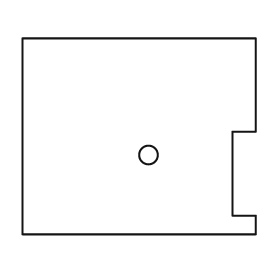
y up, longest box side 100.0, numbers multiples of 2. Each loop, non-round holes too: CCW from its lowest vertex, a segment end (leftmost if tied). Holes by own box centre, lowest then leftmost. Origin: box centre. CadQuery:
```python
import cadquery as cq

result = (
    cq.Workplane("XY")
    .moveTo(-50.0, -42.0)
    .lineTo(50.0, -42.0)
    .lineTo(50.0, -34.0)
    .lineTo(40.0, -34.0)
    .lineTo(40.0, 2.0)
    .lineTo(50.0, 2.0)
    .lineTo(50.0, 42.0)
    .lineTo(-50.0, 42.0)
    .close()
    .moveTo(4.0, -8.0)
    .circle(4.0)
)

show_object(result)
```